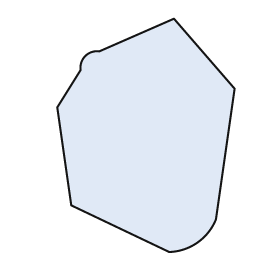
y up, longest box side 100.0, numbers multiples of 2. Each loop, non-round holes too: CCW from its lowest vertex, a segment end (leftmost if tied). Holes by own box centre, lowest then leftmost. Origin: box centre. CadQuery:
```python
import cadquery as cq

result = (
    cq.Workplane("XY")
    .moveTo(10.0, -50.0)
    .threePointArc((22.0, -46.0), (30.0, -36.0))
    .lineTo(38.0, 20.0)
    .lineTo(12.0, 50.0)
    .lineTo(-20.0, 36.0)
    .threePointArc((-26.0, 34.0), (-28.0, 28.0))
    .lineTo(-38.0, 12.0)
    .lineTo(-32.0, -30.0)
    .close()
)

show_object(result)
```